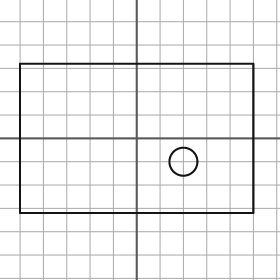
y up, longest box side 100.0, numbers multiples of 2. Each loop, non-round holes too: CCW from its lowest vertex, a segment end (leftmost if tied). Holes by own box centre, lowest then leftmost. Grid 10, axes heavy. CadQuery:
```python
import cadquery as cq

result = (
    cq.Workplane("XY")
    .moveTo(-50.0, -32.0)
    .lineTo(50.0, -32.0)
    .lineTo(50.0, 32.0)
    .lineTo(-50.0, 32.0)
    .close()
    .moveTo(20.0, -10.0)
    .circle(6.0)
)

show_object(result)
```